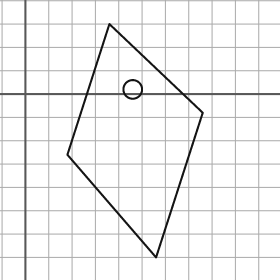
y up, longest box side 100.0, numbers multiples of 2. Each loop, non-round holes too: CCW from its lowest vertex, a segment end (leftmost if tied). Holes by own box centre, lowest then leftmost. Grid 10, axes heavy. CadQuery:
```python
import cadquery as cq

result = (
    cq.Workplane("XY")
    .moveTo(56.0, -70.0)
    .lineTo(76.0, -8.0)
    .lineTo(36.0, 30.0)
    .lineTo(18.0, -26.0)
    .close()
    .moveTo(46.0, 2.0)
    .circle(4.0)
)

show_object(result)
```